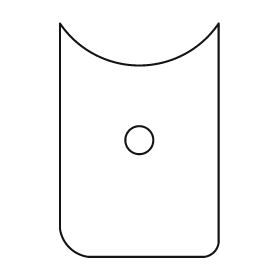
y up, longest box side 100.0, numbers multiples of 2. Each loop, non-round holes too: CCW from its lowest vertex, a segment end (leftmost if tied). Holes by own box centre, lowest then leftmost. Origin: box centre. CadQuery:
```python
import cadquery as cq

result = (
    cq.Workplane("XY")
    .moveTo(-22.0, -50.0)
    .lineTo(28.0, -50.0)
    .threePointArc((32.0, -48.0), (34.0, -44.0))
    .lineTo(34.0, 50.0)
    .threePointArc((0.0, 32.0), (-34.0, 50.0))
    .lineTo(-34.0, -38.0)
    .threePointArc((-30.0, -46.0), (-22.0, -50.0))
    .close()
    .moveTo(0.0, 0.0)
    .circle(6.0)
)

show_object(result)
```